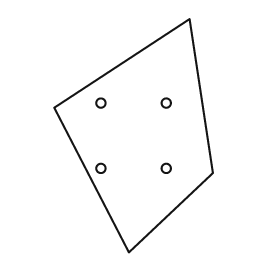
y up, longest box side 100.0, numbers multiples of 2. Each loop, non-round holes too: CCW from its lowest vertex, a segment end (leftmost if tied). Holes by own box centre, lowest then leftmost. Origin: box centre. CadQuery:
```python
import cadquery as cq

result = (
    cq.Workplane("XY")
    .moveTo(-2.0, -50.0)
    .lineTo(34.0, -16.0)
    .lineTo(24.0, 50.0)
    .lineTo(-34.0, 12.0)
    .close()
    .moveTo(-14.0, -14.0)
    .circle(2.0)
    .moveTo(14.0, -14.0)
    .circle(2.0)
    .moveTo(-14.0, 14.0)
    .circle(2.0)
    .moveTo(14.0, 14.0)
    .circle(2.0)
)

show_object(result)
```